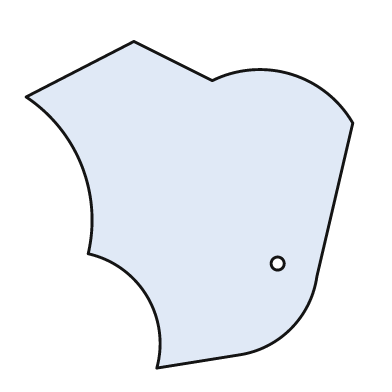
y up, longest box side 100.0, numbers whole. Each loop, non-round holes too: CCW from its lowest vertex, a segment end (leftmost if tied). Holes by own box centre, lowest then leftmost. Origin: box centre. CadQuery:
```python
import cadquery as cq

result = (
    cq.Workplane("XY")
    .moveTo(-10.0, -50.0)
    .lineTo(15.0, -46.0)
    .threePointArc((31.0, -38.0), (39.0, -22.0))
    .lineTo(50.0, 25.0)
    .threePointArc((31.0, 40.0), (7.0, 38.0))
    .lineTo(-17.0, 50.0)
    .lineTo(-50.0, 33.0)
    .threePointArc((-33.0, 12.0), (-31.0, -15.0))
    .threePointArc((-13.0, -28.0), (-10.0, -50.0))
    .close()
    .moveTo(27.0, -18.0)
    .circle(2.0)
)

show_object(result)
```